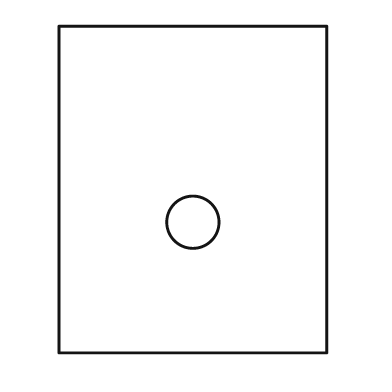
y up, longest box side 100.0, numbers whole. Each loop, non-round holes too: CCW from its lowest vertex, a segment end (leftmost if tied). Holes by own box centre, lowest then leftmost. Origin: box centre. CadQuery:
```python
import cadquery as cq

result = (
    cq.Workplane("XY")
    .moveTo(-41.0, -50.0)
    .lineTo(41.0, -50.0)
    .lineTo(41.0, 50.0)
    .lineTo(-41.0, 50.0)
    .close()
    .moveTo(0.0, -10.0)
    .circle(8.0)
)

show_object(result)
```